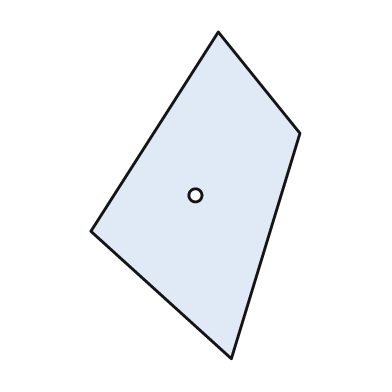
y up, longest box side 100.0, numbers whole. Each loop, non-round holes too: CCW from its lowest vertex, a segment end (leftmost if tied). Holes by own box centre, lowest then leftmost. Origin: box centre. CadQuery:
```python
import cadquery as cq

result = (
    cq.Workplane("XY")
    .moveTo(11.0, -50.0)
    .lineTo(32.0, 19.0)
    .lineTo(7.0, 50.0)
    .lineTo(-32.0, -11.0)
    .close()
    .moveTo(0.0, 0.0)
    .circle(2.0)
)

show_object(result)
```